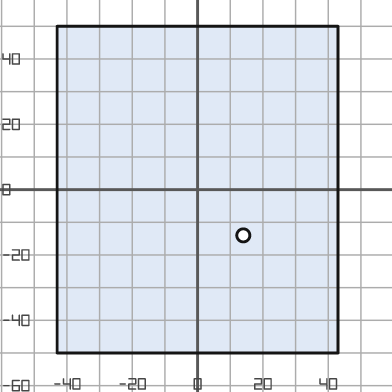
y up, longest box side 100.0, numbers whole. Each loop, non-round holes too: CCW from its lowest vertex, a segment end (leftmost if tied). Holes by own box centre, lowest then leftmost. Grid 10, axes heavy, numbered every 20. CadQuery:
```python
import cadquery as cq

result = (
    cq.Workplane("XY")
    .moveTo(-43.0, -50.0)
    .lineTo(43.0, -50.0)
    .lineTo(43.0, 50.0)
    .lineTo(-43.0, 50.0)
    .close()
    .moveTo(14.0, -14.0)
    .circle(2.0)
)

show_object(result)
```